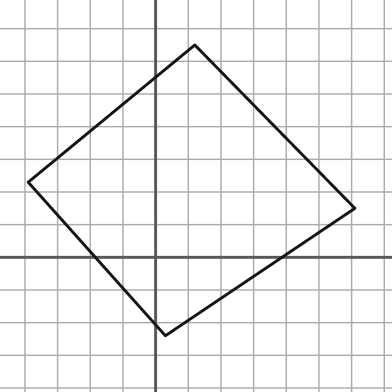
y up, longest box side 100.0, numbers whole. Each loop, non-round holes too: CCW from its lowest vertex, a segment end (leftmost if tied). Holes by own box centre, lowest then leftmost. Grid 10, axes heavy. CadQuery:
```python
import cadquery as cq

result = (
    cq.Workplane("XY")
    .moveTo(3.0, -24.0)
    .lineTo(61.0, 15.0)
    .lineTo(12.0, 65.0)
    .lineTo(-39.0, 23.0)
    .close()
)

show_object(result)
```